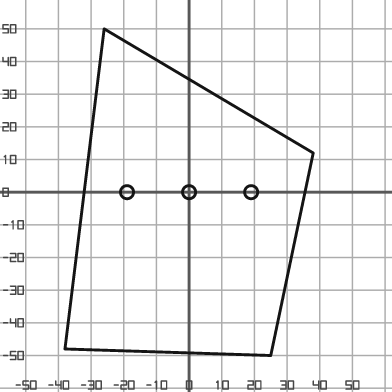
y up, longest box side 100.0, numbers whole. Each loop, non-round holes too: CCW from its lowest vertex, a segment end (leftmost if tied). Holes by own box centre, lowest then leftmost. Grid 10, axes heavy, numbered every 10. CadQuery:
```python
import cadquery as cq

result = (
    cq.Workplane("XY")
    .moveTo(25.0, -50.0)
    .lineTo(38.0, 12.0)
    .lineTo(-26.0, 50.0)
    .lineTo(-38.0, -48.0)
    .close()
    .moveTo(-19.0, 0.0)
    .circle(2.0)
    .moveTo(0.0, 0.0)
    .circle(2.0)
    .moveTo(19.0, 0.0)
    .circle(2.0)
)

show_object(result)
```